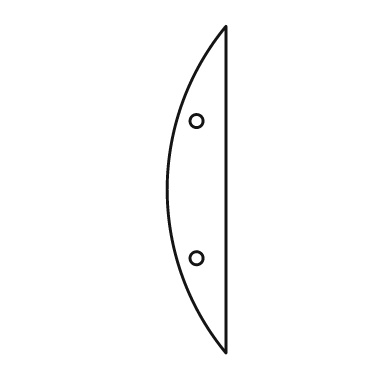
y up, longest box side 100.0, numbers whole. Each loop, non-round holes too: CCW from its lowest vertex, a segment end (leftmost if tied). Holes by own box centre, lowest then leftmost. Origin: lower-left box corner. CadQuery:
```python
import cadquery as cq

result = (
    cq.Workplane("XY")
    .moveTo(18.0, 0.0)
    .lineTo(18.0, 100.0)
    .threePointArc((0.0, 50.0), (18.0, 0.0))
    .close()
    .moveTo(9.0, 29.0)
    .circle(2.0)
    .moveTo(9.0, 71.0)
    .circle(2.0)
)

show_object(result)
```